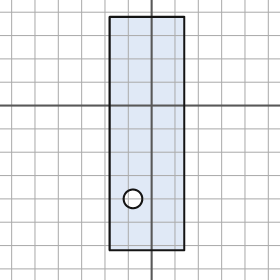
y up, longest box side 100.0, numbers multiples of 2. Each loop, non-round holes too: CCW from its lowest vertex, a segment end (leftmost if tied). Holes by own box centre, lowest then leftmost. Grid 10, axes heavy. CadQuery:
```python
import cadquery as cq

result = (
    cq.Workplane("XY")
    .moveTo(-18.0, -62.0)
    .lineTo(14.0, -62.0)
    .lineTo(14.0, 38.0)
    .lineTo(-18.0, 38.0)
    .close()
    .moveTo(-8.0, -40.0)
    .circle(4.0)
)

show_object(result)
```